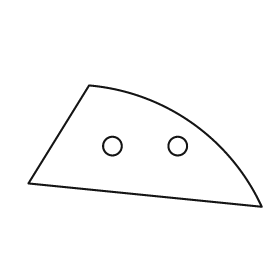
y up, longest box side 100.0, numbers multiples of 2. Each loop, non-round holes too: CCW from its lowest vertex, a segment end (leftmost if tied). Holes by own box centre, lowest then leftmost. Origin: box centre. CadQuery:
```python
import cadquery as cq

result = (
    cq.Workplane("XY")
    .moveTo(50.0, -26.0)
    .threePointArc((20.0, 10.0), (-24.0, 26.0))
    .lineTo(-50.0, -16.0)
    .close()
    .moveTo(-14.0, 0.0)
    .circle(4.0)
    .moveTo(14.0, 0.0)
    .circle(4.0)
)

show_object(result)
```